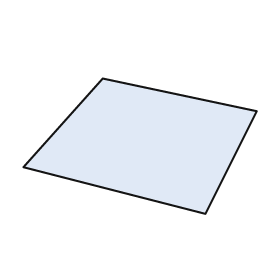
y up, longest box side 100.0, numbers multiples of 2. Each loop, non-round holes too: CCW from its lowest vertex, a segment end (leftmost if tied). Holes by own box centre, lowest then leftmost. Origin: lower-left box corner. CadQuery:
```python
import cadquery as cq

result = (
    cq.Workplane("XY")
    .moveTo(78.0, 0.0)
    .lineTo(100.0, 44.0)
    .lineTo(34.0, 58.0)
    .lineTo(0.0, 20.0)
    .close()
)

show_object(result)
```